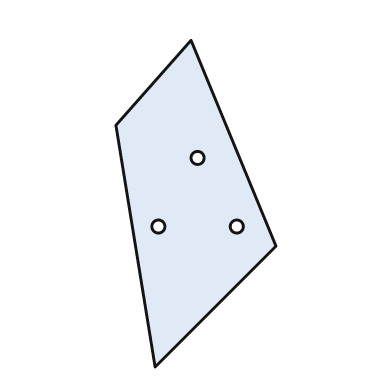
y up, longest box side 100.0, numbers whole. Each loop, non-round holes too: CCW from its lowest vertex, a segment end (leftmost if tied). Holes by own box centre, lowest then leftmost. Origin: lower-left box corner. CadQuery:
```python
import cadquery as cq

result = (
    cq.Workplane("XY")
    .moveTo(12.0, 0.0)
    .lineTo(49.0, 37.0)
    .lineTo(23.0, 100.0)
    .lineTo(0.0, 74.0)
    .close()
    .moveTo(13.0, 43.0)
    .circle(2.0)
    .moveTo(37.0, 43.0)
    .circle(2.0)
    .moveTo(25.0, 64.0)
    .circle(2.0)
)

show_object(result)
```